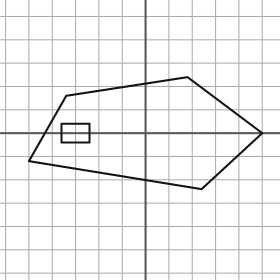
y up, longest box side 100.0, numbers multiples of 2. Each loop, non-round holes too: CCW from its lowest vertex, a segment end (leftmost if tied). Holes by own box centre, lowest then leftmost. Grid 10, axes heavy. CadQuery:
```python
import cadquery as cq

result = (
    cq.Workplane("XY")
    .moveTo(24.0, -24.0)
    .lineTo(50.0, 0.0)
    .lineTo(18.0, 24.0)
    .lineTo(-34.0, 16.0)
    .lineTo(-50.0, -12.0)
    .close()
    .moveTo(-36.0, -4.0)
    .lineTo(-24.0, -4.0)
    .lineTo(-24.0, 4.0)
    .lineTo(-36.0, 4.0)
    .close()
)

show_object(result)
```